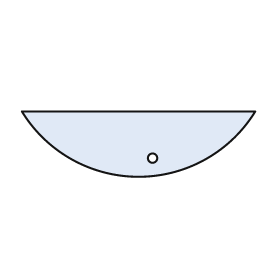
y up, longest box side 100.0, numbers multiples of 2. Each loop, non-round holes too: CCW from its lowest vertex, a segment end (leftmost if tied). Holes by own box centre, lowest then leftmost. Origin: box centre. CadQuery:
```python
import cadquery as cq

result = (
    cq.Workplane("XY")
    .moveTo(-50.0, 14.0)
    .threePointArc((0.0, -14.0), (50.0, 14.0))
    .close()
    .moveTo(6.0, -6.0)
    .circle(2.0)
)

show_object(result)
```